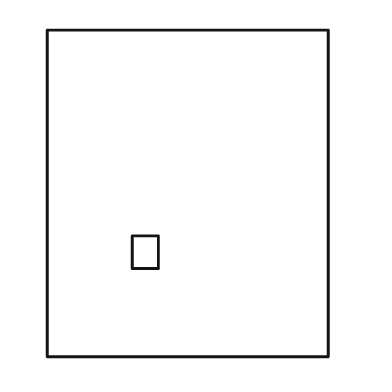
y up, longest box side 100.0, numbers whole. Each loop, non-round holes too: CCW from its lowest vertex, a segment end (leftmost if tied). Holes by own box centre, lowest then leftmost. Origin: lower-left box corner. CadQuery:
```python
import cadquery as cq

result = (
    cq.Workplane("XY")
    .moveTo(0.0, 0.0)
    .lineTo(86.0, 0.0)
    .lineTo(86.0, 100.0)
    .lineTo(0.0, 100.0)
    .close()
    .moveTo(26.0, 27.0)
    .lineTo(34.0, 27.0)
    .lineTo(34.0, 37.0)
    .lineTo(26.0, 37.0)
    .close()
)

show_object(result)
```